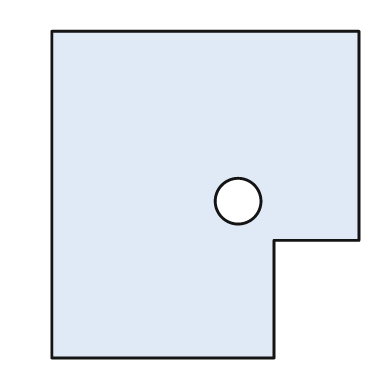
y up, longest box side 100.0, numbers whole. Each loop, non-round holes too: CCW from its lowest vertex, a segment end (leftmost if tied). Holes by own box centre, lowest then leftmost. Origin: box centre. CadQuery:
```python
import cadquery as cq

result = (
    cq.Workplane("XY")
    .moveTo(-47.0, -50.0)
    .lineTo(21.0, -50.0)
    .lineTo(21.0, -14.0)
    .lineTo(47.0, -14.0)
    .lineTo(47.0, 50.0)
    .lineTo(-47.0, 50.0)
    .close()
    .moveTo(10.0, -2.0)
    .circle(7.0)
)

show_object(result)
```